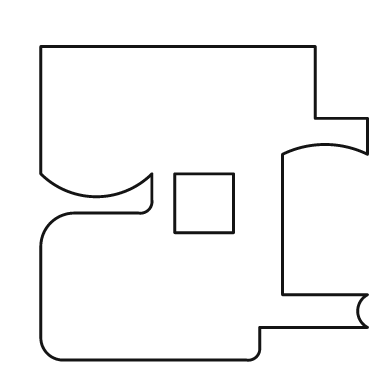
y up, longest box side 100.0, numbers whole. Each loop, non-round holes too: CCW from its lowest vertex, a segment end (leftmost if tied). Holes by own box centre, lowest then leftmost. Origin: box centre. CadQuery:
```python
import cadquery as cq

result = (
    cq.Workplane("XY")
    .moveTo(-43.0, -48.0)
    .lineTo(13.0, -48.0)
    .threePointArc((16.0, -47.0), (17.0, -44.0))
    .lineTo(17.0, -38.0)
    .lineTo(50.0, -38.0)
    .threePointArc((47.0, -33.0), (50.0, -28.0))
    .lineTo(24.0, -28.0)
    .lineTo(24.0, 15.0)
    .threePointArc((37.0, 18.0), (50.0, 15.0))
    .lineTo(50.0, 26.0)
    .lineTo(34.0, 26.0)
    .lineTo(34.0, 48.0)
    .lineTo(-50.0, 48.0)
    .lineTo(-50.0, 9.0)
    .threePointArc((-33.0, 2.0), (-16.0, 9.0))
    .lineTo(-16.0, 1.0)
    .threePointArc((-17.0, -2.0), (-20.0, -3.0))
    .lineTo(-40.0, -3.0)
    .threePointArc((-47.0, -6.0), (-50.0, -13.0))
    .lineTo(-50.0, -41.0)
    .threePointArc((-48.0, -46.0), (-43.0, -48.0))
    .close()
    .moveTo(-9.0, -9.0)
    .lineTo(9.0, -9.0)
    .lineTo(9.0, 9.0)
    .lineTo(-9.0, 9.0)
    .close()
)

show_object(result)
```